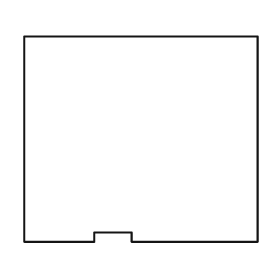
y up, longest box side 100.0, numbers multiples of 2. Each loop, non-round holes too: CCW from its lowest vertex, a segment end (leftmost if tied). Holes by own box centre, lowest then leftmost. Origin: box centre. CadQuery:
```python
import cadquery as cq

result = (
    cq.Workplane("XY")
    .moveTo(-50.0, -44.0)
    .lineTo(-20.0, -44.0)
    .lineTo(-20.0, -40.0)
    .lineTo(-4.0, -40.0)
    .lineTo(-4.0, -44.0)
    .lineTo(50.0, -44.0)
    .lineTo(50.0, 44.0)
    .lineTo(-50.0, 44.0)
    .close()
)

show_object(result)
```